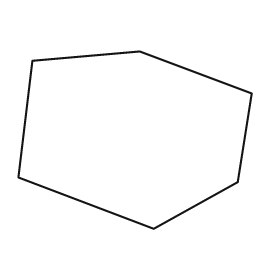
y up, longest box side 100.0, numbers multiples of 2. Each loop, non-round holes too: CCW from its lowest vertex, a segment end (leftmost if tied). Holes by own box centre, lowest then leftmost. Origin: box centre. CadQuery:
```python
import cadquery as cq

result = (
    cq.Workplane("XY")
    .moveTo(8.0, -38.0)
    .lineTo(44.0, -18.0)
    .lineTo(50.0, 20.0)
    .lineTo(2.0, 38.0)
    .lineTo(-44.0, 34.0)
    .lineTo(-50.0, -16.0)
    .close()
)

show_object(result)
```